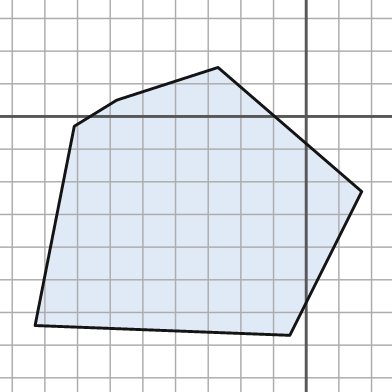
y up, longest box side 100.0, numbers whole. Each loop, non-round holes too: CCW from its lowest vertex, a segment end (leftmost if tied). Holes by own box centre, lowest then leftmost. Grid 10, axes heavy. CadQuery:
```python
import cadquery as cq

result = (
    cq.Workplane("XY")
    .moveTo(-5.0, -67.0)
    .lineTo(17.0, -23.0)
    .lineTo(-27.0, 15.0)
    .lineTo(-58.0, 5.0)
    .lineTo(-71.0, -3.0)
    .lineTo(-83.0, -64.0)
    .close()
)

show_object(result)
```